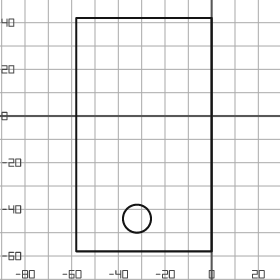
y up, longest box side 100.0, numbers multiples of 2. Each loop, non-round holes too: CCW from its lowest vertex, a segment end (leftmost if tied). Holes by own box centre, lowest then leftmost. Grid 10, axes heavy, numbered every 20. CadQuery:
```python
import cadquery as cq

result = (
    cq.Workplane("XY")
    .moveTo(-58.0, -58.0)
    .lineTo(0.0, -58.0)
    .lineTo(0.0, 42.0)
    .lineTo(-58.0, 42.0)
    .close()
    .moveTo(-32.0, -44.0)
    .circle(6.0)
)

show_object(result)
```